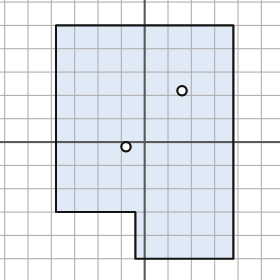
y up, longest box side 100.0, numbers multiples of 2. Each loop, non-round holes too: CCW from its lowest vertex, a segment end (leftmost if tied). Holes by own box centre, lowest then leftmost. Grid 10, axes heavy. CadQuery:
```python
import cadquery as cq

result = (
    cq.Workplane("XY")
    .moveTo(-4.0, -50.0)
    .lineTo(38.0, -50.0)
    .lineTo(38.0, 50.0)
    .lineTo(-38.0, 50.0)
    .lineTo(-38.0, -30.0)
    .lineTo(-4.0, -30.0)
    .close()
    .moveTo(-8.0, -2.0)
    .circle(2.0)
    .moveTo(16.0, 22.0)
    .circle(2.0)
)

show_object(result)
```